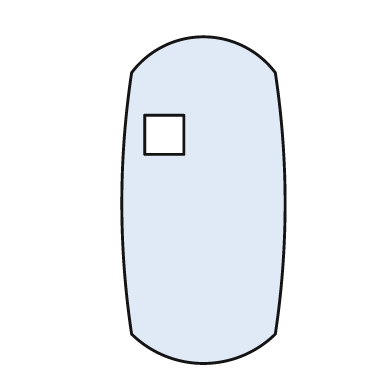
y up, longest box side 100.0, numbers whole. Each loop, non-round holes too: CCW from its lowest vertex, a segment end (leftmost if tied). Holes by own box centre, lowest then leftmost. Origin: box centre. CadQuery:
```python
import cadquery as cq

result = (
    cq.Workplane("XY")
    .moveTo(-22.0, -41.0)
    .threePointArc((0.0, -50.0), (22.0, -41.0))
    .threePointArc((25.0, -1.0), (22.0, 39.0))
    .threePointArc((0.0, 50.0), (-22.0, 39.0))
    .threePointArc((-25.0, -1.0), (-22.0, -41.0))
    .close()
    .moveTo(-18.0, 14.0)
    .lineTo(-6.0, 14.0)
    .lineTo(-6.0, 26.0)
    .lineTo(-18.0, 26.0)
    .close()
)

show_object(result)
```